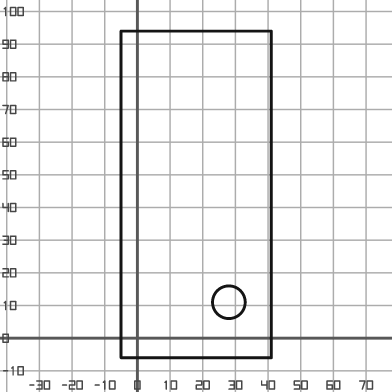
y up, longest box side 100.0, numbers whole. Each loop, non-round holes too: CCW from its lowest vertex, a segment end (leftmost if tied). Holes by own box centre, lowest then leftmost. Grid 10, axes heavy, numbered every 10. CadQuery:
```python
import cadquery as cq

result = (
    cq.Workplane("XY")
    .moveTo(-5.0, -6.0)
    .lineTo(41.0, -6.0)
    .lineTo(41.0, 94.0)
    .lineTo(-5.0, 94.0)
    .close()
    .moveTo(28.0, 11.0)
    .circle(5.0)
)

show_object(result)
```